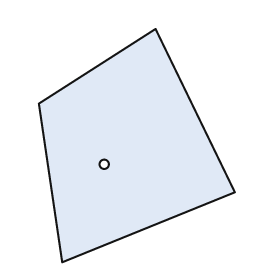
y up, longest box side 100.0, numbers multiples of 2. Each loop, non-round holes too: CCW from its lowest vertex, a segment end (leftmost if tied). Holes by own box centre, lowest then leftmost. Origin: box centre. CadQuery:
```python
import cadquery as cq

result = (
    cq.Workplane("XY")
    .moveTo(-32.0, -50.0)
    .lineTo(42.0, -20.0)
    .lineTo(8.0, 50.0)
    .lineTo(-42.0, 18.0)
    .close()
    .moveTo(-14.0, -8.0)
    .circle(2.0)
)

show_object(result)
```